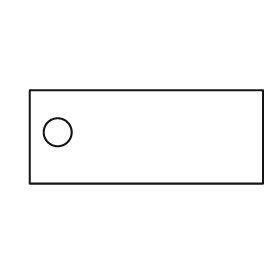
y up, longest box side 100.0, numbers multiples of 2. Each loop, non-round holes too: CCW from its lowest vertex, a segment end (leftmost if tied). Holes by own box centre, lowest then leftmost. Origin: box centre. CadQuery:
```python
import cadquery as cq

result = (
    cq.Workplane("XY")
    .moveTo(-50.0, -20.0)
    .lineTo(50.0, -20.0)
    .lineTo(50.0, 20.0)
    .lineTo(-50.0, 20.0)
    .close()
    .moveTo(-38.0, 2.0)
    .circle(6.0)
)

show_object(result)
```